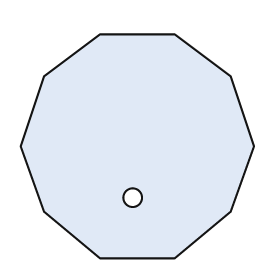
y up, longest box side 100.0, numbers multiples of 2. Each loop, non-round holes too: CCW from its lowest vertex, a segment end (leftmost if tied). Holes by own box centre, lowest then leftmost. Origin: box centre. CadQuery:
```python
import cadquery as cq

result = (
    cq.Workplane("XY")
    .moveTo(-16.0, -48.0)
    .lineTo(16.0, -48.0)
    .lineTo(40.0, -28.0)
    .lineTo(50.0, 0.0)
    .lineTo(40.0, 30.0)
    .lineTo(16.0, 48.0)
    .lineTo(-16.0, 48.0)
    .lineTo(-40.0, 30.0)
    .lineTo(-50.0, 0.0)
    .lineTo(-40.0, -28.0)
    .close()
    .moveTo(-2.0, -22.0)
    .circle(4.0)
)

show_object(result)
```